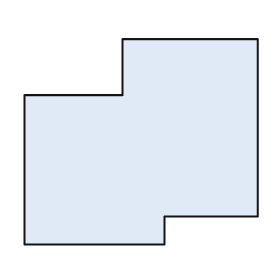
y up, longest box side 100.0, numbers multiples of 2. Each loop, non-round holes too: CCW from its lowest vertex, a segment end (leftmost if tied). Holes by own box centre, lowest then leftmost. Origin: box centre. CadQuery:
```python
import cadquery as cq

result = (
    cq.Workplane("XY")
    .moveTo(-50.0, -44.0)
    .lineTo(10.0, -44.0)
    .lineTo(10.0, -32.0)
    .lineTo(50.0, -32.0)
    .lineTo(50.0, 44.0)
    .lineTo(-8.0, 44.0)
    .lineTo(-8.0, 20.0)
    .lineTo(-50.0, 20.0)
    .close()
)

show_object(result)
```